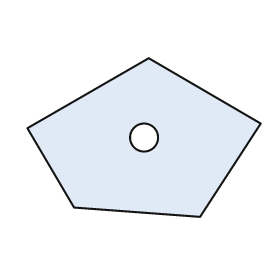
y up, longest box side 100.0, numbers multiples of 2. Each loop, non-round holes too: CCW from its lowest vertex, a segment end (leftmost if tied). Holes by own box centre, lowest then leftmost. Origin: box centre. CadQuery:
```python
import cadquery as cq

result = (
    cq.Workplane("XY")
    .moveTo(24.0, -34.0)
    .lineTo(50.0, 6.0)
    .lineTo(2.0, 34.0)
    .lineTo(-50.0, 4.0)
    .lineTo(-30.0, -30.0)
    .close()
    .moveTo(0.0, 0.0)
    .circle(6.0)
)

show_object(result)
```